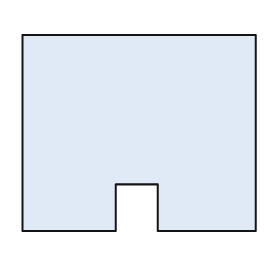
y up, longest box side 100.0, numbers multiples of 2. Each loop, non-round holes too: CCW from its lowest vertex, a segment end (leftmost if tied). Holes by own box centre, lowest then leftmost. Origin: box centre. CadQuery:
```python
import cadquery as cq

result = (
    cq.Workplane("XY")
    .moveTo(-50.0, -42.0)
    .lineTo(-10.0, -42.0)
    .lineTo(-10.0, -22.0)
    .lineTo(8.0, -22.0)
    .lineTo(8.0, -42.0)
    .lineTo(50.0, -42.0)
    .lineTo(50.0, 42.0)
    .lineTo(-50.0, 42.0)
    .close()
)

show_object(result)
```